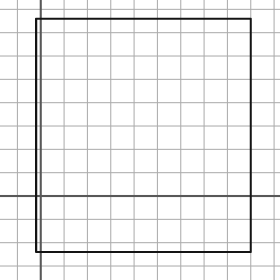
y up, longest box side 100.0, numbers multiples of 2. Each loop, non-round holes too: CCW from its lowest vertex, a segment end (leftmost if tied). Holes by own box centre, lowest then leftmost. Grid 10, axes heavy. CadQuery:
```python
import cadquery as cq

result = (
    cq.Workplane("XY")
    .moveTo(-2.0, -24.0)
    .lineTo(90.0, -24.0)
    .lineTo(90.0, 76.0)
    .lineTo(-2.0, 76.0)
    .close()
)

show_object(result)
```